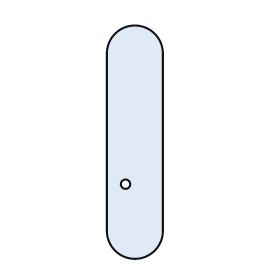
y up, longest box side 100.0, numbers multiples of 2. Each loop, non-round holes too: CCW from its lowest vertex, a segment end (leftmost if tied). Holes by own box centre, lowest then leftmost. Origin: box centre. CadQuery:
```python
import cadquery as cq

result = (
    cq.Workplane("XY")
    .moveTo(-12.0, -38.0)
    .threePointArc((0.0, -50.0), (12.0, -38.0))
    .lineTo(12.0, 38.0)
    .threePointArc((0.0, 50.0), (-12.0, 38.0))
    .close()
    .moveTo(-4.0, -18.0)
    .circle(2.0)
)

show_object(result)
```